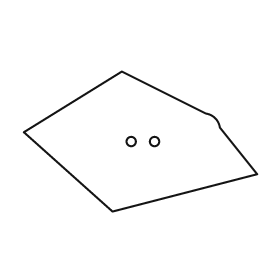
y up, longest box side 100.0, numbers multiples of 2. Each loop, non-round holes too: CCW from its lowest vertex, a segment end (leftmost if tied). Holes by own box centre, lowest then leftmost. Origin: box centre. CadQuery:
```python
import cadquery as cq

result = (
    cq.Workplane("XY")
    .moveTo(-12.0, -30.0)
    .lineTo(50.0, -14.0)
    .lineTo(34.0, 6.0)
    .threePointArc((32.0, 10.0), (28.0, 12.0))
    .lineTo(-8.0, 30.0)
    .lineTo(-50.0, 4.0)
    .close()
    .moveTo(-4.0, 0.0)
    .circle(2.0)
    .moveTo(6.0, 0.0)
    .circle(2.0)
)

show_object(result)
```